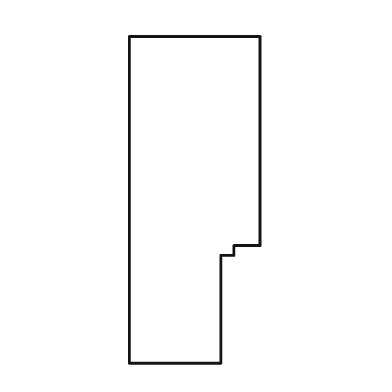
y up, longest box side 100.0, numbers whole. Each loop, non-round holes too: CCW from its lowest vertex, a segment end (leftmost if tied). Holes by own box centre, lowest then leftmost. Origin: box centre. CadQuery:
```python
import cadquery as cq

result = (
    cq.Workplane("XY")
    .moveTo(-20.0, -50.0)
    .lineTo(8.0, -50.0)
    .lineTo(8.0, -17.0)
    .lineTo(12.0, -17.0)
    .lineTo(12.0, -14.0)
    .lineTo(20.0, -14.0)
    .lineTo(20.0, 50.0)
    .lineTo(-20.0, 50.0)
    .close()
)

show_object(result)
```